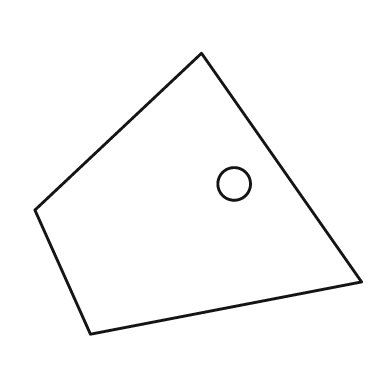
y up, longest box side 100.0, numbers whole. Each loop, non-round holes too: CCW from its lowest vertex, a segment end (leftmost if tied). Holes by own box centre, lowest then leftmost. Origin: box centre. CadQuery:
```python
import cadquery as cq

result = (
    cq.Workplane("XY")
    .moveTo(-33.0, -43.0)
    .lineTo(50.0, -27.0)
    .lineTo(1.0, 43.0)
    .lineTo(-50.0, -5.0)
    .close()
    .moveTo(11.0, 3.0)
    .circle(5.0)
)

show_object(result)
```